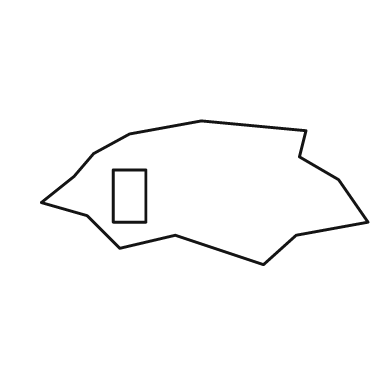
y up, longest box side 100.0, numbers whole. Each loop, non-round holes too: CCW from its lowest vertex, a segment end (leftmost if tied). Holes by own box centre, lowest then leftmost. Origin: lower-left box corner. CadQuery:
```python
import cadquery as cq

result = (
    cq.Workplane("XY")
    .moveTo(68.0, 0.0)
    .lineTo(78.0, 9.0)
    .lineTo(100.0, 13.0)
    .lineTo(91.0, 26.0)
    .lineTo(79.0, 33.0)
    .lineTo(81.0, 41.0)
    .lineTo(49.0, 44.0)
    .lineTo(27.0, 40.0)
    .lineTo(16.0, 34.0)
    .lineTo(10.0, 27.0)
    .lineTo(0.0, 19.0)
    .lineTo(14.0, 15.0)
    .lineTo(24.0, 5.0)
    .lineTo(41.0, 9.0)
    .close()
    .moveTo(22.0, 13.0)
    .lineTo(32.0, 13.0)
    .lineTo(32.0, 29.0)
    .lineTo(22.0, 29.0)
    .close()
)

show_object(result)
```